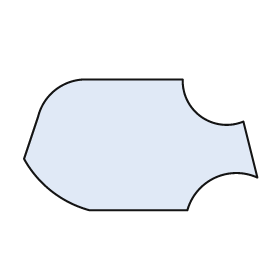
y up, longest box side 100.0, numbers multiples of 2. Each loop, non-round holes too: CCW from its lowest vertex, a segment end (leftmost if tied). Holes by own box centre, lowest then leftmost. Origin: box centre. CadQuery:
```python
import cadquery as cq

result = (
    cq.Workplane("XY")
    .moveTo(-22.0, -28.0)
    .lineTo(20.0, -28.0)
    .threePointArc((32.0, -14.0), (50.0, -14.0))
    .lineTo(44.0, 10.0)
    .threePointArc((26.0, 12.0), (18.0, 28.0))
    .lineTo(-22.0, 28.0)
    .threePointArc((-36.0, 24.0), (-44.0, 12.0))
    .lineTo(-50.0, -6.0)
    .threePointArc((-38.0, -20.0), (-22.0, -28.0))
    .close()
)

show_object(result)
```